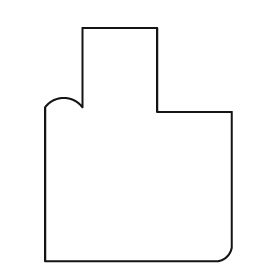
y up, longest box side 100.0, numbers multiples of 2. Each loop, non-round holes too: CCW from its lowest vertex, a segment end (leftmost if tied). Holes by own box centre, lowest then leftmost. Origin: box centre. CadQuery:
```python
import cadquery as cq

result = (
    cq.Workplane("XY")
    .moveTo(-40.0, -50.0)
    .lineTo(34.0, -50.0)
    .threePointArc((38.0, -48.0), (40.0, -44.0))
    .lineTo(40.0, 14.0)
    .lineTo(8.0, 14.0)
    .lineTo(8.0, 50.0)
    .lineTo(-24.0, 50.0)
    .lineTo(-24.0, 16.0)
    .threePointArc((-32.0, 20.0), (-40.0, 16.0))
    .close()
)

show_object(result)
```